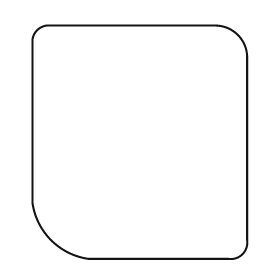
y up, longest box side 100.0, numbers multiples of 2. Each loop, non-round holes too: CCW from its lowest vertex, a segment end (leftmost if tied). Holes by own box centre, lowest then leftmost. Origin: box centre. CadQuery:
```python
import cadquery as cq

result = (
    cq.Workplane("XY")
    .moveTo(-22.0, -50.0)
    .lineTo(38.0, -50.0)
    .threePointArc((44.0, -48.0), (46.0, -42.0))
    .lineTo(46.0, 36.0)
    .threePointArc((42.0, 46.0), (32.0, 50.0))
    .lineTo(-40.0, 50.0)
    .threePointArc((-44.0, 48.0), (-46.0, 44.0))
    .lineTo(-46.0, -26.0)
    .threePointArc((-38.0, -42.0), (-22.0, -50.0))
    .close()
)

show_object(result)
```